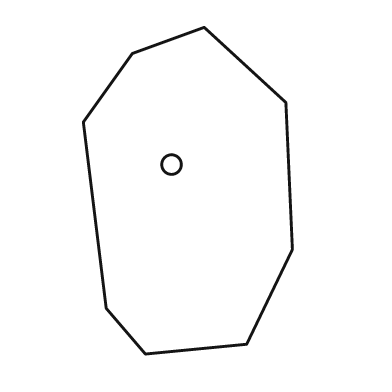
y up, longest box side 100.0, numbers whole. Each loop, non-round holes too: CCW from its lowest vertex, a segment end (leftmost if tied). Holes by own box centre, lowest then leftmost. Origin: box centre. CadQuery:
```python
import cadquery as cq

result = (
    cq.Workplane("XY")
    .moveTo(-13.0, -50.0)
    .lineTo(18.0, -47.0)
    .lineTo(32.0, -18.0)
    .lineTo(30.0, 27.0)
    .lineTo(5.0, 50.0)
    .lineTo(-17.0, 42.0)
    .lineTo(-32.0, 21.0)
    .lineTo(-25.0, -36.0)
    .close()
    .moveTo(-5.0, 8.0)
    .circle(3.0)
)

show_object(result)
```